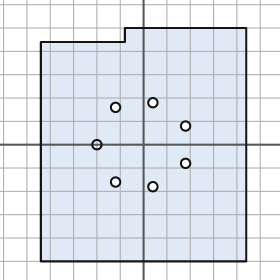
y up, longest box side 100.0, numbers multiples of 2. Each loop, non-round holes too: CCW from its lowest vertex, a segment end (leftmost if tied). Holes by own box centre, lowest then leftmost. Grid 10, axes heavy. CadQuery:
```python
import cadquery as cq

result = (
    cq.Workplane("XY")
    .moveTo(-44.0, -50.0)
    .lineTo(44.0, -50.0)
    .lineTo(44.0, 50.0)
    .lineTo(-8.0, 50.0)
    .lineTo(-8.0, 44.0)
    .lineTo(-44.0, 44.0)
    .close()
    .moveTo(4.0, -18.0)
    .circle(2.0)
    .moveTo(-12.0, -16.0)
    .circle(2.0)
    .moveTo(18.0, -8.0)
    .circle(2.0)
    .moveTo(-20.0, 0.0)
    .circle(2.0)
    .moveTo(18.0, 8.0)
    .circle(2.0)
    .moveTo(-12.0, 16.0)
    .circle(2.0)
    .moveTo(4.0, 18.0)
    .circle(2.0)
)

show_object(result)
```